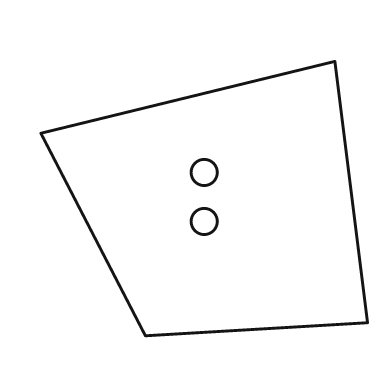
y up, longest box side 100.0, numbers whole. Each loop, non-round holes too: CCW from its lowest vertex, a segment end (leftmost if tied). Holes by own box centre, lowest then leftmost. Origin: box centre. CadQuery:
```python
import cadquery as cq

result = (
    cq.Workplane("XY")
    .moveTo(-18.0, -42.0)
    .lineTo(50.0, -38.0)
    .lineTo(40.0, 42.0)
    .lineTo(-50.0, 20.0)
    .close()
    .moveTo(0.0, -7.0)
    .circle(4.0)
    .moveTo(0.0, 8.0)
    .circle(4.0)
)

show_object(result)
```